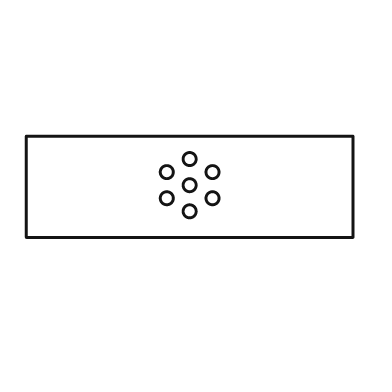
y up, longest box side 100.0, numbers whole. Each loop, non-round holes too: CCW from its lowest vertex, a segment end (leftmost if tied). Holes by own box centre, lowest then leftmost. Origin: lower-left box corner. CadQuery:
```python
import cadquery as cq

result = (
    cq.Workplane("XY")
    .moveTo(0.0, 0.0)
    .lineTo(100.0, 0.0)
    .lineTo(100.0, 31.0)
    .lineTo(0.0, 31.0)
    .close()
    .moveTo(50.0, 8.0)
    .circle(2.0)
    .moveTo(43.0, 12.0)
    .circle(2.0)
    .moveTo(57.0, 12.0)
    .circle(2.0)
    .moveTo(50.0, 16.0)
    .circle(2.0)
    .moveTo(43.0, 20.0)
    .circle(2.0)
    .moveTo(57.0, 20.0)
    .circle(2.0)
    .moveTo(50.0, 24.0)
    .circle(2.0)
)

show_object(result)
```